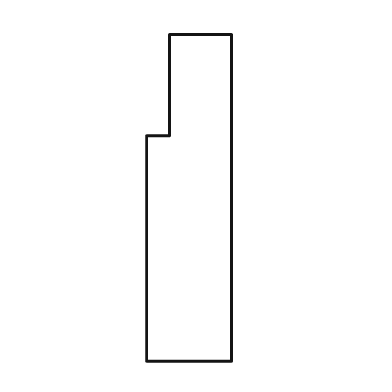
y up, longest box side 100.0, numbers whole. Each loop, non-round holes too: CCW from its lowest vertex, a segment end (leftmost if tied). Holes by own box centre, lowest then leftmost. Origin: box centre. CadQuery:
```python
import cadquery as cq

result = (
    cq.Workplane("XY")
    .moveTo(-13.0, -50.0)
    .lineTo(13.0, -50.0)
    .lineTo(13.0, 50.0)
    .lineTo(-6.0, 50.0)
    .lineTo(-6.0, 19.0)
    .lineTo(-13.0, 19.0)
    .close()
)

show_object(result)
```